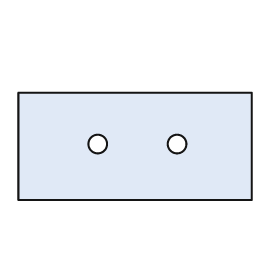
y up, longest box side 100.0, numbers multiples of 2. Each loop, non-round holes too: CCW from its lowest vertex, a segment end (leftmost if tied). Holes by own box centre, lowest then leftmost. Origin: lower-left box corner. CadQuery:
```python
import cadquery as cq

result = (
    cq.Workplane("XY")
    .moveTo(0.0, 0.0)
    .lineTo(100.0, 0.0)
    .lineTo(100.0, 46.0)
    .lineTo(0.0, 46.0)
    .close()
    .moveTo(34.0, 24.0)
    .circle(4.0)
    .moveTo(68.0, 24.0)
    .circle(4.0)
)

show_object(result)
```